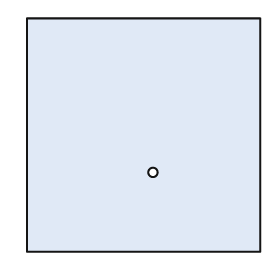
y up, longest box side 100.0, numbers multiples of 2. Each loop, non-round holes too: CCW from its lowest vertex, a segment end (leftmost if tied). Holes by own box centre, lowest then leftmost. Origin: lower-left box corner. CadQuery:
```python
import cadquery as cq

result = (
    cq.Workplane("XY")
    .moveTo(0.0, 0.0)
    .lineTo(100.0, 0.0)
    .lineTo(100.0, 100.0)
    .lineTo(0.0, 100.0)
    .close()
    .moveTo(54.0, 34.0)
    .circle(2.0)
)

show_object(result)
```